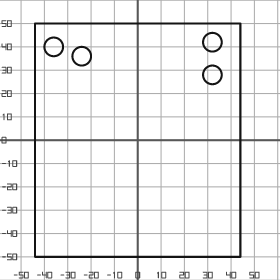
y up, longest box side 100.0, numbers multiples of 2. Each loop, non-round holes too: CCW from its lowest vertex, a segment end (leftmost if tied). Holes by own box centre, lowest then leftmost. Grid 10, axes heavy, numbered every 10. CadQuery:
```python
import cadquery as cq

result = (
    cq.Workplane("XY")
    .moveTo(-44.0, -50.0)
    .lineTo(44.0, -50.0)
    .lineTo(44.0, 50.0)
    .lineTo(-44.0, 50.0)
    .close()
    .moveTo(32.0, 28.0)
    .circle(4.0)
    .moveTo(-24.0, 36.0)
    .circle(4.0)
    .moveTo(-36.0, 40.0)
    .circle(4.0)
    .moveTo(32.0, 42.0)
    .circle(4.0)
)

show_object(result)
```